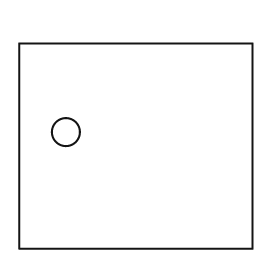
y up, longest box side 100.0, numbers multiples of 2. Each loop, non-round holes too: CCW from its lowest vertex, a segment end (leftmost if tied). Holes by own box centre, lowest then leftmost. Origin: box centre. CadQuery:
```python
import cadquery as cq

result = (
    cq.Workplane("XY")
    .moveTo(-50.0, -44.0)
    .lineTo(50.0, -44.0)
    .lineTo(50.0, 44.0)
    .lineTo(-50.0, 44.0)
    .close()
    .moveTo(-30.0, 6.0)
    .circle(6.0)
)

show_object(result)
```